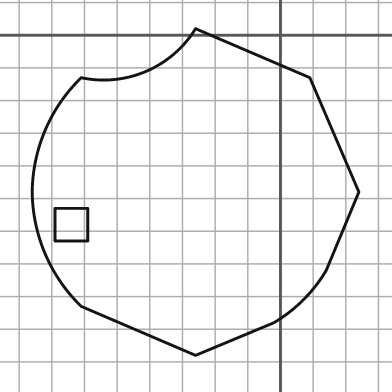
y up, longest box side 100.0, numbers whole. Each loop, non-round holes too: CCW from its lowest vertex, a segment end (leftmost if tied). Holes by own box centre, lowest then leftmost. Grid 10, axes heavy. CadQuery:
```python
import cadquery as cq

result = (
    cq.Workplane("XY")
    .moveTo(-26.0, -98.0)
    .lineTo(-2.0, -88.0)
    .threePointArc((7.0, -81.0), (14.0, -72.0))
    .lineTo(24.0, -48.0)
    .lineTo(9.0, -13.0)
    .lineTo(-26.0, 2.0)
    .threePointArc((-41.0, -11.0), (-61.0, -13.0))
    .threePointArc((-72.0, -29.0), (-76.0, -48.0))
    .threePointArc((-72.0, -67.0), (-61.0, -83.0))
    .close()
    .moveTo(-69.0, -63.0)
    .lineTo(-59.0, -63.0)
    .lineTo(-59.0, -53.0)
    .lineTo(-69.0, -53.0)
    .close()
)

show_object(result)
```